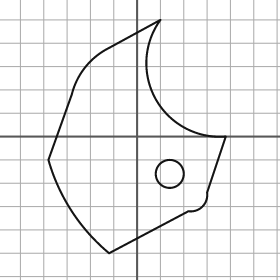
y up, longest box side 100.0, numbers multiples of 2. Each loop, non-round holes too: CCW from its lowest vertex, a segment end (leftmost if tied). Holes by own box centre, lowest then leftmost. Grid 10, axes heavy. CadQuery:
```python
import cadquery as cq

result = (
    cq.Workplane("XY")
    .moveTo(-12.0, -50.0)
    .lineTo(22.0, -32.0)
    .threePointArc((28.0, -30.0), (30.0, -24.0))
    .lineTo(38.0, 0.0)
    .threePointArc((8.0, 16.0), (10.0, 50.0))
    .lineTo(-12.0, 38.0)
    .threePointArc((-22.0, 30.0), (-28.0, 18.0))
    .lineTo(-38.0, -10.0)
    .threePointArc((-28.0, -32.0), (-12.0, -50.0))
    .close()
    .moveTo(14.0, -16.0)
    .circle(6.0)
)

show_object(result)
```